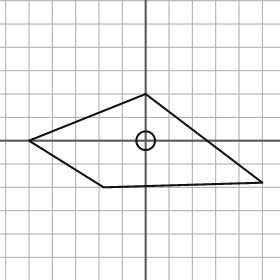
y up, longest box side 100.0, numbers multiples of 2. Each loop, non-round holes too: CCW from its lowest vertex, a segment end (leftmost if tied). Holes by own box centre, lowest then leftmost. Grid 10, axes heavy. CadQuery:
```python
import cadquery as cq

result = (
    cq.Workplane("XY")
    .moveTo(-18.0, -20.0)
    .lineTo(50.0, -18.0)
    .lineTo(0.0, 20.0)
    .lineTo(-50.0, 0.0)
    .close()
    .moveTo(0.0, 0.0)
    .circle(4.0)
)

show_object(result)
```